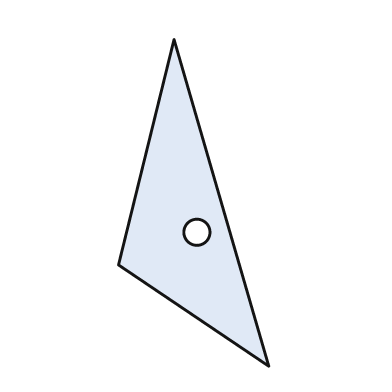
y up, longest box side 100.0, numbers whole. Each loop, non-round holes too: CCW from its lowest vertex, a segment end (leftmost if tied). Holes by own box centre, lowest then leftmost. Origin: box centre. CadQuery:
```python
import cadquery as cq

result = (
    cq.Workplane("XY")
    .moveTo(23.0, -50.0)
    .lineTo(-6.0, 50.0)
    .lineTo(-23.0, -19.0)
    .close()
    .moveTo(1.0, -9.0)
    .circle(4.0)
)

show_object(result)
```